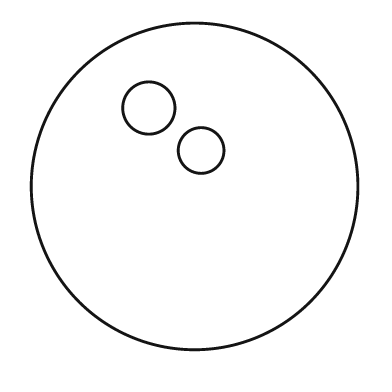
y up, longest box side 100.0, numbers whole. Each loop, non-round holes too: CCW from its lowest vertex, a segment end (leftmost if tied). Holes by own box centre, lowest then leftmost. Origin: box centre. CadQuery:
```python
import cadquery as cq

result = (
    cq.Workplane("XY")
    .moveTo(0.0, 0.0)
    .circle(50.0)
    .moveTo(2.0, 11.0)
    .circle(7.0)
    .moveTo(-14.0, 24.0)
    .circle(8.0)
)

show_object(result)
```